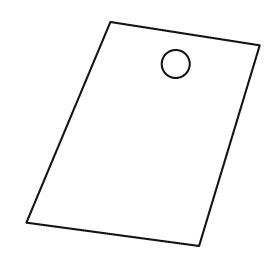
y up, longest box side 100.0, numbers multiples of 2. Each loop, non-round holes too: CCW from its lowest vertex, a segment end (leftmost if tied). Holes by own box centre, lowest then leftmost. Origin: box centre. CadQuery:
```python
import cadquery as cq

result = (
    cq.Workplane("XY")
    .moveTo(24.0, -48.0)
    .lineTo(50.0, 38.0)
    .lineTo(-14.0, 48.0)
    .lineTo(-50.0, -38.0)
    .close()
    .moveTo(14.0, 30.0)
    .circle(6.0)
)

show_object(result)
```